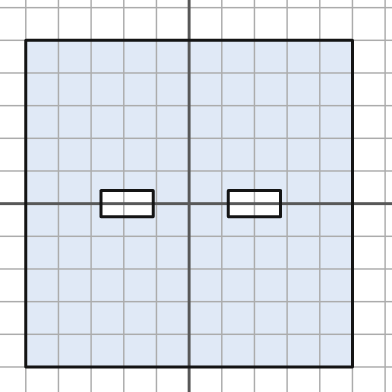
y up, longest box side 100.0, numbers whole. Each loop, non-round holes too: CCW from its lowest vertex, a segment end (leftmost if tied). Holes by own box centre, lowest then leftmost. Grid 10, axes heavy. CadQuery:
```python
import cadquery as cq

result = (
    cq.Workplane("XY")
    .moveTo(-50.0, -50.0)
    .lineTo(50.0, -50.0)
    .lineTo(50.0, 50.0)
    .lineTo(-50.0, 50.0)
    .close()
    .moveTo(-27.0, -4.0)
    .lineTo(-11.0, -4.0)
    .lineTo(-11.0, 4.0)
    .lineTo(-27.0, 4.0)
    .close()
    .moveTo(12.0, -4.0)
    .lineTo(28.0, -4.0)
    .lineTo(28.0, 4.0)
    .lineTo(12.0, 4.0)
    .close()
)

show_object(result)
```